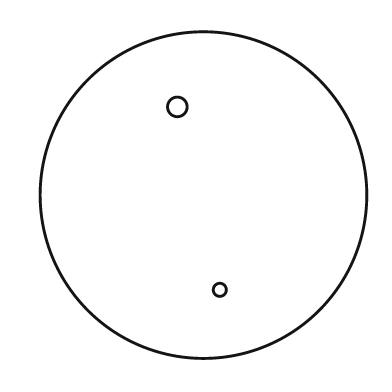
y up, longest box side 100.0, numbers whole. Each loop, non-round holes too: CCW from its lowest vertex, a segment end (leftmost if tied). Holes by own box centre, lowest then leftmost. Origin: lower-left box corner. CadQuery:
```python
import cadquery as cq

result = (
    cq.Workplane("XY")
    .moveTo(50.0, 50.0)
    .circle(50.0)
    .moveTo(55.0, 21.0)
    .circle(2.0)
    .moveTo(42.0, 77.0)
    .circle(3.0)
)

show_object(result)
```